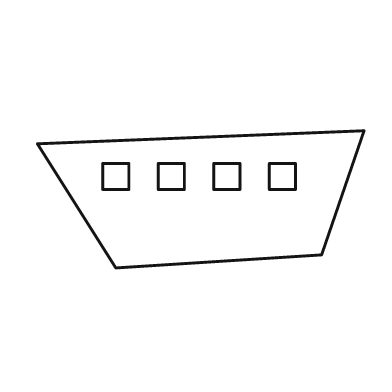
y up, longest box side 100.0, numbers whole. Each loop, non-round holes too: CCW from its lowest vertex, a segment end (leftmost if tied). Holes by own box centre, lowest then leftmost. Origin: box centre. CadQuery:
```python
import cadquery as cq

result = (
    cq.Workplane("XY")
    .moveTo(-26.0, -21.0)
    .lineTo(37.0, -17.0)
    .lineTo(50.0, 21.0)
    .lineTo(-50.0, 17.0)
    .close()
    .moveTo(-30.0, 3.0)
    .lineTo(-22.0, 3.0)
    .lineTo(-22.0, 11.0)
    .lineTo(-30.0, 11.0)
    .close()
    .moveTo(-13.0, 3.0)
    .lineTo(-5.0, 3.0)
    .lineTo(-5.0, 11.0)
    .lineTo(-13.0, 11.0)
    .close()
    .moveTo(4.0, 3.0)
    .lineTo(12.0, 3.0)
    .lineTo(12.0, 11.0)
    .lineTo(4.0, 11.0)
    .close()
    .moveTo(21.0, 3.0)
    .lineTo(29.0, 3.0)
    .lineTo(29.0, 11.0)
    .lineTo(21.0, 11.0)
    .close()
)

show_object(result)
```